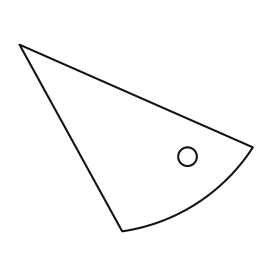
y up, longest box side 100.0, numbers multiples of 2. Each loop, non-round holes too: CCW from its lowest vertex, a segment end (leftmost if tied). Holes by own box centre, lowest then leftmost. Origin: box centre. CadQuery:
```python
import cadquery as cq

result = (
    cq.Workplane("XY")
    .moveTo(-6.0, -40.0)
    .threePointArc((26.0, -28.0), (50.0, -4.0))
    .lineTo(-50.0, 40.0)
    .close()
    .moveTo(22.0, -8.0)
    .circle(4.0)
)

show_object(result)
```